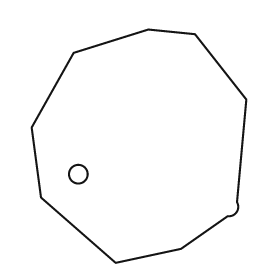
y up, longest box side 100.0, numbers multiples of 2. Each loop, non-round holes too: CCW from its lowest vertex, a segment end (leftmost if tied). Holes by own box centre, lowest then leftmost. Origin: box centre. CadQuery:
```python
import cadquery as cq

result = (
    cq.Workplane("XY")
    .moveTo(-10.0, -50.0)
    .lineTo(18.0, -44.0)
    .lineTo(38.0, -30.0)
    .threePointArc((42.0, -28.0), (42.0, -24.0))
    .lineTo(46.0, 20.0)
    .lineTo(24.0, 48.0)
    .lineTo(4.0, 50.0)
    .lineTo(-28.0, 40.0)
    .lineTo(-46.0, 8.0)
    .lineTo(-42.0, -22.0)
    .close()
    .moveTo(-26.0, -12.0)
    .circle(4.0)
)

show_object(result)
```